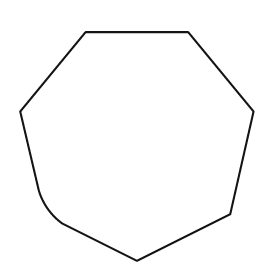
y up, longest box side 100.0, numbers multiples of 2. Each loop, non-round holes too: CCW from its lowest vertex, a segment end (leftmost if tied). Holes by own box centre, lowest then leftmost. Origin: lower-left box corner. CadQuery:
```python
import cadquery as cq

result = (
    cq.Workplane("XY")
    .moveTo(50.0, 0.0)
    .lineTo(90.0, 20.0)
    .lineTo(100.0, 64.0)
    .lineTo(72.0, 98.0)
    .lineTo(28.0, 98.0)
    .lineTo(0.0, 64.0)
    .lineTo(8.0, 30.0)
    .threePointArc((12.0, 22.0), (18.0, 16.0))
    .close()
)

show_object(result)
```